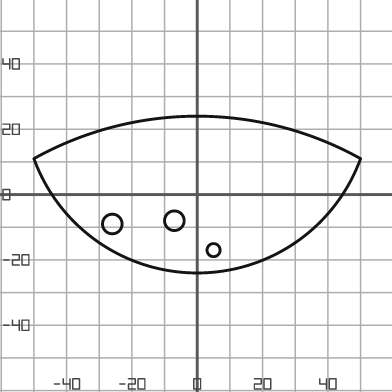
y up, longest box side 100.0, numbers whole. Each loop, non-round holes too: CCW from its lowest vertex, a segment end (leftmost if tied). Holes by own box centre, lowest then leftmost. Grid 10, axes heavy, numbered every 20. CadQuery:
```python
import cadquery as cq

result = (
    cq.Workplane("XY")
    .moveTo(-50.0, 11.0)
    .threePointArc((0.0, -24.0), (50.0, 11.0))
    .threePointArc((0.0, 24.0), (-50.0, 11.0))
    .close()
    .moveTo(5.0, -17.0)
    .circle(2.0)
    .moveTo(-26.0, -9.0)
    .circle(3.0)
    .moveTo(-7.0, -8.0)
    .circle(3.0)
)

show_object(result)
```